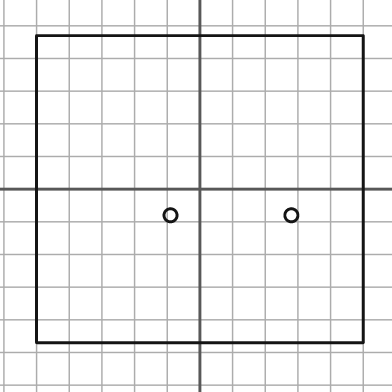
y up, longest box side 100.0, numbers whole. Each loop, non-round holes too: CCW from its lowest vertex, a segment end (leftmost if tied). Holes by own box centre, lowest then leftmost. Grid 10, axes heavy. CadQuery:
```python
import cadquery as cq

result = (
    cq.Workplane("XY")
    .moveTo(-50.0, -47.0)
    .lineTo(50.0, -47.0)
    .lineTo(50.0, 47.0)
    .lineTo(-50.0, 47.0)
    .close()
    .moveTo(-9.0, -8.0)
    .circle(2.0)
    .moveTo(28.0, -8.0)
    .circle(2.0)
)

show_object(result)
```